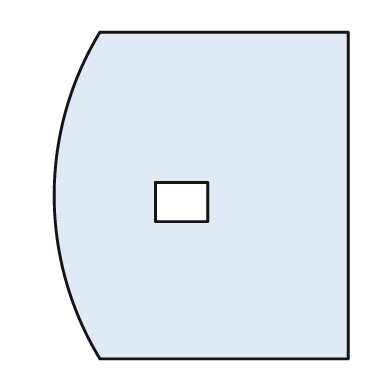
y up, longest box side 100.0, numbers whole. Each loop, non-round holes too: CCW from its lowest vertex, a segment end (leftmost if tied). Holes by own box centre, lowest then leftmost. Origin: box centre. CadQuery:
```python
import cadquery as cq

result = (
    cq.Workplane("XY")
    .moveTo(-31.0, -50.0)
    .lineTo(45.0, -50.0)
    .lineTo(45.0, 50.0)
    .lineTo(-31.0, 50.0)
    .threePointArc((-45.0, 0.0), (-31.0, -50.0))
    .close()
    .moveTo(-14.0, -8.0)
    .lineTo(2.0, -8.0)
    .lineTo(2.0, 4.0)
    .lineTo(-14.0, 4.0)
    .close()
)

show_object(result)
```